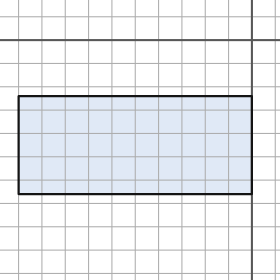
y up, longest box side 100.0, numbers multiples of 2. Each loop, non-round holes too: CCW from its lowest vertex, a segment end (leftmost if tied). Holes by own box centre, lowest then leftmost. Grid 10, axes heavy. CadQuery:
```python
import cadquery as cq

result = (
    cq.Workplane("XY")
    .moveTo(-100.0, -66.0)
    .lineTo(0.0, -66.0)
    .lineTo(0.0, -24.0)
    .lineTo(-100.0, -24.0)
    .close()
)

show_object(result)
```